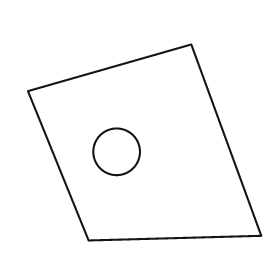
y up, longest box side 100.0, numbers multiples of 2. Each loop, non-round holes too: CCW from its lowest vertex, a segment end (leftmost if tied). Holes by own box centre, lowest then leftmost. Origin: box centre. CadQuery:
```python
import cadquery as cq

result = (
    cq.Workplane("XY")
    .moveTo(-24.0, -42.0)
    .lineTo(50.0, -40.0)
    .lineTo(20.0, 42.0)
    .lineTo(-50.0, 22.0)
    .close()
    .moveTo(-12.0, -4.0)
    .circle(10.0)
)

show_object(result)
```